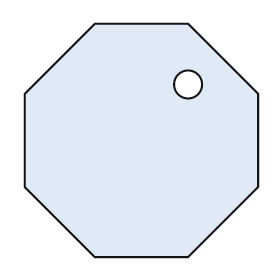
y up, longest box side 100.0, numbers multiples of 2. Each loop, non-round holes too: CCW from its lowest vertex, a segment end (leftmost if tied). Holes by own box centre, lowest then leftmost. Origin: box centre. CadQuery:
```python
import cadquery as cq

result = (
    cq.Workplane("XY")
    .moveTo(-20.0, -50.0)
    .lineTo(20.0, -50.0)
    .lineTo(50.0, -20.0)
    .lineTo(50.0, 20.0)
    .lineTo(20.0, 50.0)
    .lineTo(-20.0, 50.0)
    .lineTo(-50.0, 20.0)
    .lineTo(-50.0, -20.0)
    .close()
    .moveTo(20.0, 24.0)
    .circle(6.0)
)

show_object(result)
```